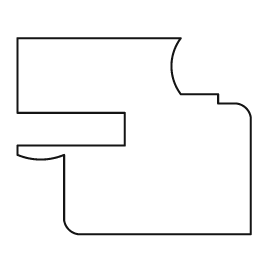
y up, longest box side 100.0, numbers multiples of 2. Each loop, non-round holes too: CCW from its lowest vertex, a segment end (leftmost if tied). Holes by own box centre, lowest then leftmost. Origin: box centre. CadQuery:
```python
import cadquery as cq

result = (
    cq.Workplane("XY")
    .moveTo(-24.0, -42.0)
    .lineTo(50.0, -42.0)
    .lineTo(50.0, 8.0)
    .threePointArc((48.0, 12.0), (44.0, 14.0))
    .lineTo(36.0, 14.0)
    .lineTo(36.0, 18.0)
    .lineTo(20.0, 18.0)
    .threePointArc((16.0, 30.0), (20.0, 42.0))
    .lineTo(-50.0, 42.0)
    .lineTo(-50.0, 10.0)
    .lineTo(-4.0, 10.0)
    .lineTo(-4.0, -4.0)
    .lineTo(-50.0, -4.0)
    .lineTo(-50.0, -8.0)
    .threePointArc((-40.0, -10.0), (-30.0, -8.0))
    .lineTo(-30.0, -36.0)
    .threePointArc((-28.0, -40.0), (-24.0, -42.0))
    .close()
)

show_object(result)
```